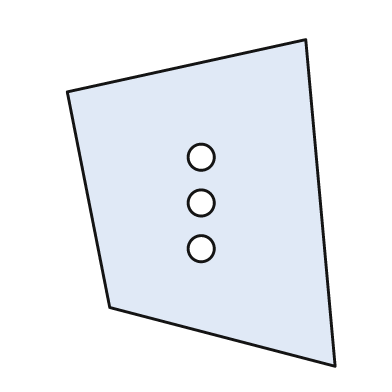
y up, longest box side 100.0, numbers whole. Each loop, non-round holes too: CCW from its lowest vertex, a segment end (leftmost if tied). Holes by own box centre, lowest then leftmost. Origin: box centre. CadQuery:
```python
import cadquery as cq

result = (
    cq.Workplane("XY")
    .moveTo(41.0, -50.0)
    .lineTo(32.0, 50.0)
    .lineTo(-41.0, 34.0)
    .lineTo(-28.0, -32.0)
    .close()
    .moveTo(0.0, -14.0)
    .circle(4.0)
    .moveTo(0.0, 0.0)
    .circle(4.0)
    .moveTo(0.0, 14.0)
    .circle(4.0)
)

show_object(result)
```